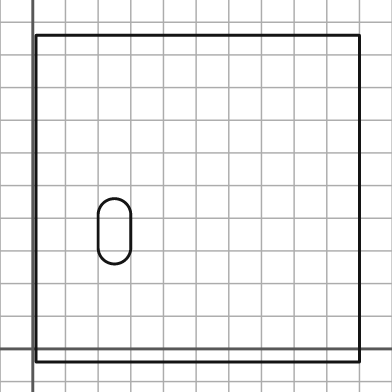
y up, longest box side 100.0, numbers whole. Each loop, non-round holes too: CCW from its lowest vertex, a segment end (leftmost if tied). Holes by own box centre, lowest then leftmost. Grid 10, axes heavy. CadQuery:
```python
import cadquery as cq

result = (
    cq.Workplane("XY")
    .moveTo(1.0, -4.0)
    .lineTo(100.0, -4.0)
    .lineTo(100.0, 96.0)
    .lineTo(1.0, 96.0)
    .close()
    .moveTo(20.0, 31.0)
    .threePointArc((25.0, 26.0), (30.0, 31.0))
    .lineTo(30.0, 41.0)
    .threePointArc((25.0, 46.0), (20.0, 41.0))
    .close()
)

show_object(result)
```